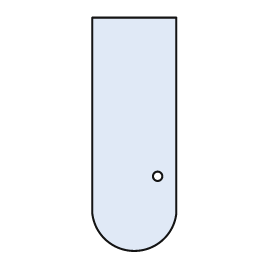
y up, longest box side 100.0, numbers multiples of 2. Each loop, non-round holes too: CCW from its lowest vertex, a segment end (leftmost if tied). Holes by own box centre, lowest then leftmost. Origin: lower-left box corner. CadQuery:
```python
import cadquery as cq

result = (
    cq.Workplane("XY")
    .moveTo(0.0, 16.0)
    .threePointArc((18.0, 0.0), (36.0, 16.0))
    .lineTo(36.0, 100.0)
    .lineTo(0.0, 100.0)
    .close()
    .moveTo(28.0, 32.0)
    .circle(2.0)
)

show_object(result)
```